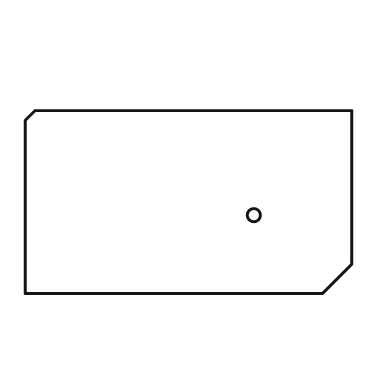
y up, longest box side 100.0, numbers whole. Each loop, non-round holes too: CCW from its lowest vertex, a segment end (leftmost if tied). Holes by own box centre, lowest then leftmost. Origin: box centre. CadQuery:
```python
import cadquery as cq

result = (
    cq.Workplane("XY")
    .moveTo(-50.0, -28.0)
    .lineTo(41.0, -28.0)
    .lineTo(50.0, -19.0)
    .lineTo(50.0, 28.0)
    .lineTo(-47.0, 28.0)
    .lineTo(-50.0, 25.0)
    .close()
    .moveTo(20.0, -4.0)
    .circle(2.0)
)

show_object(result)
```